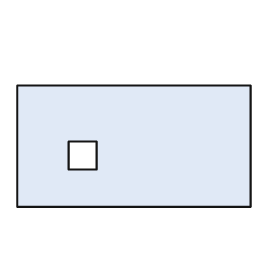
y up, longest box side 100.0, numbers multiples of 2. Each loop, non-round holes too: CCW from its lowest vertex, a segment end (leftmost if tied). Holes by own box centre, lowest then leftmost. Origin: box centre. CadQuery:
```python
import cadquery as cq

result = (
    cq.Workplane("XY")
    .moveTo(-50.0, -26.0)
    .lineTo(50.0, -26.0)
    .lineTo(50.0, 26.0)
    .lineTo(-50.0, 26.0)
    .close()
    .moveTo(-28.0, -10.0)
    .lineTo(-16.0, -10.0)
    .lineTo(-16.0, 2.0)
    .lineTo(-28.0, 2.0)
    .close()
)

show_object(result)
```